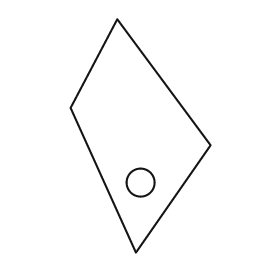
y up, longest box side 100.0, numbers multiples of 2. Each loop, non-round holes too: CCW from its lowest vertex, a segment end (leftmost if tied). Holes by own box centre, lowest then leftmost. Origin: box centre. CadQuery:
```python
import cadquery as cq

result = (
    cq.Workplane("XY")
    .moveTo(-2.0, -50.0)
    .lineTo(30.0, -4.0)
    .lineTo(-10.0, 50.0)
    .lineTo(-30.0, 12.0)
    .close()
    .moveTo(0.0, -20.0)
    .circle(6.0)
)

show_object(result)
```